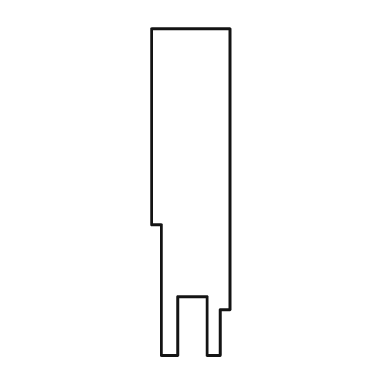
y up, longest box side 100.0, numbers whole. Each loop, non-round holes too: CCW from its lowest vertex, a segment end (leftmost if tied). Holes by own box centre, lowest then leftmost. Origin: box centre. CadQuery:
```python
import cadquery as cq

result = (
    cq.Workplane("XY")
    .moveTo(-9.0, -50.0)
    .lineTo(-4.0, -50.0)
    .lineTo(-4.0, -32.0)
    .lineTo(5.0, -32.0)
    .lineTo(5.0, -50.0)
    .lineTo(9.0, -50.0)
    .lineTo(9.0, -36.0)
    .lineTo(12.0, -36.0)
    .lineTo(12.0, 50.0)
    .lineTo(-12.0, 50.0)
    .lineTo(-12.0, -10.0)
    .lineTo(-9.0, -10.0)
    .close()
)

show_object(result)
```